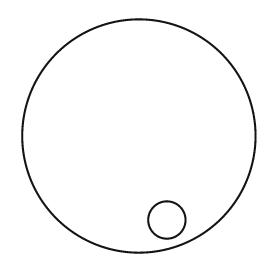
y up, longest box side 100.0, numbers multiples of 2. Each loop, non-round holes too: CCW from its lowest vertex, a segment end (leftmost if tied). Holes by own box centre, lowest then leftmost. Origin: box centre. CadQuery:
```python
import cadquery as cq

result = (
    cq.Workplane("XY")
    .moveTo(0.0, 0.0)
    .circle(50.0)
    .moveTo(12.0, -36.0)
    .circle(8.0)
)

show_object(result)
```